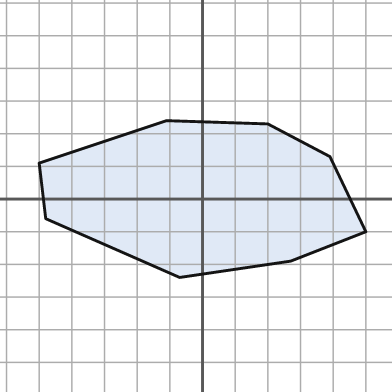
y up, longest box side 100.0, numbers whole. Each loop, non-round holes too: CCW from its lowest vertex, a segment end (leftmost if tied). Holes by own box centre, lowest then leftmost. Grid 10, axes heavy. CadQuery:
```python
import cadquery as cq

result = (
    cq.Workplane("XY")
    .moveTo(-7.0, -24.0)
    .lineTo(27.0, -19.0)
    .lineTo(50.0, -10.0)
    .lineTo(39.0, 13.0)
    .lineTo(20.0, 23.0)
    .lineTo(-11.0, 24.0)
    .lineTo(-50.0, 11.0)
    .lineTo(-48.0, -6.0)
    .close()
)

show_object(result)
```